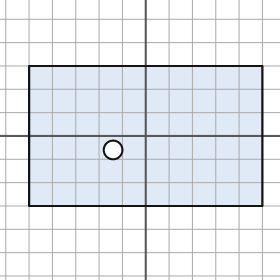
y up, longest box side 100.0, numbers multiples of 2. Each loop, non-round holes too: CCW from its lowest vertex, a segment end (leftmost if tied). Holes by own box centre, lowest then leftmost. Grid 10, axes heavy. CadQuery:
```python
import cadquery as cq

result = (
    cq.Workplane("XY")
    .moveTo(-50.0, -30.0)
    .lineTo(50.0, -30.0)
    .lineTo(50.0, 30.0)
    .lineTo(-50.0, 30.0)
    .close()
    .moveTo(-14.0, -6.0)
    .circle(4.0)
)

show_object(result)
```